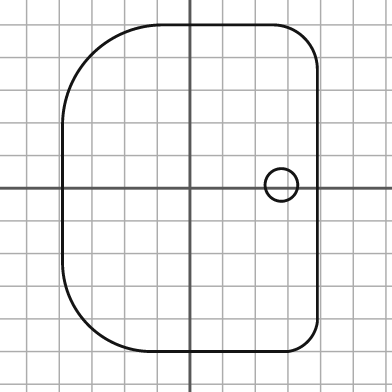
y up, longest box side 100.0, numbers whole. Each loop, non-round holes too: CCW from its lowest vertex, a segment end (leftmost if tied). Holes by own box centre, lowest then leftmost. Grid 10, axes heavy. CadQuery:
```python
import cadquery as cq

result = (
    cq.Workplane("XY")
    .moveTo(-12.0, -50.0)
    .lineTo(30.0, -50.0)
    .threePointArc((36.0, -47.0), (39.0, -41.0))
    .lineTo(39.0, 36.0)
    .threePointArc((35.0, 46.0), (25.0, 50.0))
    .lineTo(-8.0, 50.0)
    .threePointArc((-30.0, 41.0), (-39.0, 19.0))
    .lineTo(-39.0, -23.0)
    .threePointArc((-31.0, -42.0), (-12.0, -50.0))
    .close()
    .moveTo(28.0, 1.0)
    .circle(5.0)
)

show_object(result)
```